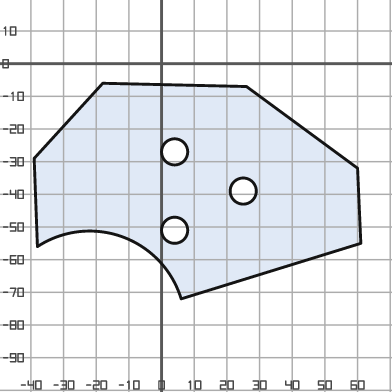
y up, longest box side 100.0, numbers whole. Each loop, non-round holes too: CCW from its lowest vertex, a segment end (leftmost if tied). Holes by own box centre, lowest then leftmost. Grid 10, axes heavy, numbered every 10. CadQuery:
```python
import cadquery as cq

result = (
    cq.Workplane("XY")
    .moveTo(6.0, -72.0)
    .lineTo(61.0, -55.0)
    .lineTo(60.0, -32.0)
    .lineTo(26.0, -7.0)
    .lineTo(-18.0, -6.0)
    .lineTo(-39.0, -29.0)
    .lineTo(-38.0, -56.0)
    .threePointArc((-12.0, -53.0), (6.0, -72.0))
    .close()
    .moveTo(4.0, -51.0)
    .circle(4.0)
    .moveTo(25.0, -39.0)
    .circle(4.0)
    .moveTo(4.0, -27.0)
    .circle(4.0)
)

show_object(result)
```